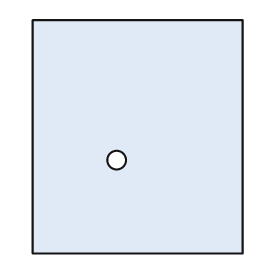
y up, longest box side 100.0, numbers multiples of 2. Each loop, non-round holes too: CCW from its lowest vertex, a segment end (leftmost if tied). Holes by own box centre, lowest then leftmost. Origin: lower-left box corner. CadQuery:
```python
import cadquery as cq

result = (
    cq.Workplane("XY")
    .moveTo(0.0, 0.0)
    .lineTo(90.0, 0.0)
    .lineTo(90.0, 100.0)
    .lineTo(0.0, 100.0)
    .close()
    .moveTo(36.0, 40.0)
    .circle(4.0)
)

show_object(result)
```